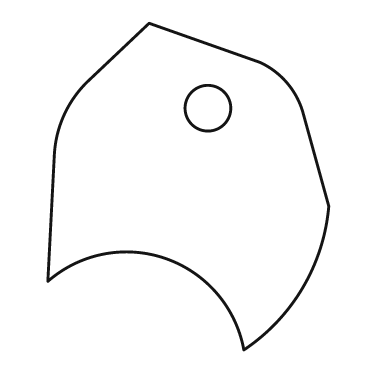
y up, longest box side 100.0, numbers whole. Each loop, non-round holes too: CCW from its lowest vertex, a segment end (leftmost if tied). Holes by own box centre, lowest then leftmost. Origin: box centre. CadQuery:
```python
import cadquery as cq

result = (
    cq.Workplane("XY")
    .moveTo(17.0, -50.0)
    .threePointArc((35.0, -31.0), (43.0, -6.0))
    .lineTo(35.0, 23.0)
    .threePointArc((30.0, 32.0), (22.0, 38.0))
    .lineTo(-12.0, 50.0)
    .lineTo(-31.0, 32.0)
    .threePointArc((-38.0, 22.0), (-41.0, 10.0))
    .lineTo(-43.0, -29.0)
    .threePointArc((-7.0, -22.0), (17.0, -50.0))
    .close()
    .moveTo(6.0, 24.0)
    .circle(7.0)
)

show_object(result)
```